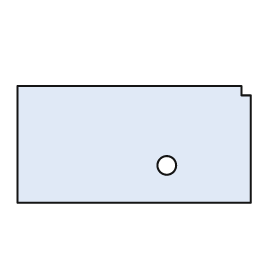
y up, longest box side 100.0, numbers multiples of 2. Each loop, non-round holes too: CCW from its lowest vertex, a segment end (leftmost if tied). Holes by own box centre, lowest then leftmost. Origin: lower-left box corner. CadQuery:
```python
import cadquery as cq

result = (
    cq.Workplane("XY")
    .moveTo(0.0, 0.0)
    .lineTo(100.0, 0.0)
    .lineTo(100.0, 46.0)
    .lineTo(96.0, 46.0)
    .lineTo(96.0, 50.0)
    .lineTo(0.0, 50.0)
    .close()
    .moveTo(64.0, 16.0)
    .circle(4.0)
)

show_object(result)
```